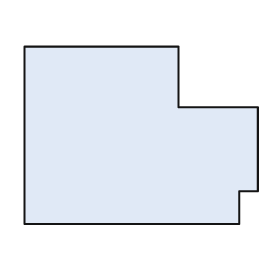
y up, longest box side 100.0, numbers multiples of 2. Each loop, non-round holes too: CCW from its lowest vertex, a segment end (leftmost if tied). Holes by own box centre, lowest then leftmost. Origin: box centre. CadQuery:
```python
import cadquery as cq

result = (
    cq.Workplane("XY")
    .moveTo(-50.0, -38.0)
    .lineTo(42.0, -38.0)
    .lineTo(42.0, -24.0)
    .lineTo(50.0, -24.0)
    .lineTo(50.0, 12.0)
    .lineTo(16.0, 12.0)
    .lineTo(16.0, 38.0)
    .lineTo(-50.0, 38.0)
    .close()
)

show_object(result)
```